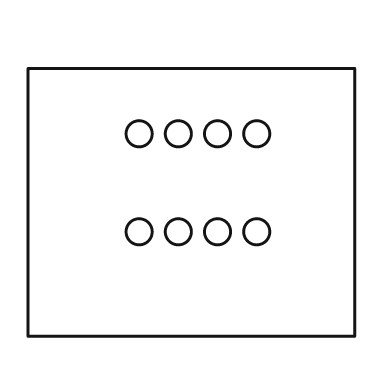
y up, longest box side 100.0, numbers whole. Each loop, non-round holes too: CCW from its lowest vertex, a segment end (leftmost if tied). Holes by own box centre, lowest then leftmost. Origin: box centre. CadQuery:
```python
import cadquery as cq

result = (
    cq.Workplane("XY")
    .moveTo(-50.0, -41.0)
    .lineTo(50.0, -41.0)
    .lineTo(50.0, 41.0)
    .lineTo(-50.0, 41.0)
    .close()
    .moveTo(-16.0, -9.0)
    .circle(4.0)
    .moveTo(-4.0, -9.0)
    .circle(4.0)
    .moveTo(8.0, -9.0)
    .circle(4.0)
    .moveTo(20.0, -9.0)
    .circle(4.0)
    .moveTo(-16.0, 21.0)
    .circle(4.0)
    .moveTo(-4.0, 21.0)
    .circle(4.0)
    .moveTo(8.0, 21.0)
    .circle(4.0)
    .moveTo(20.0, 21.0)
    .circle(4.0)
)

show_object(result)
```